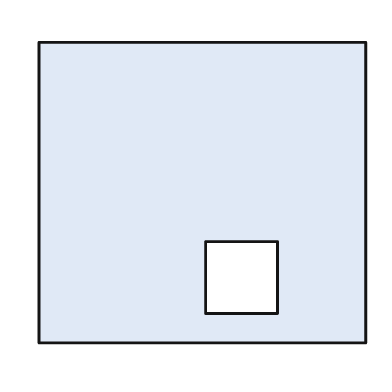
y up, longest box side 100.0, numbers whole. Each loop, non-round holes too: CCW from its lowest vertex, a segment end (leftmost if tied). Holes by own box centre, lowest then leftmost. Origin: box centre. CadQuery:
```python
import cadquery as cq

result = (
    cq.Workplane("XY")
    .moveTo(-50.0, -46.0)
    .lineTo(50.0, -46.0)
    .lineTo(50.0, 46.0)
    .lineTo(-50.0, 46.0)
    .close()
    .moveTo(1.0, -37.0)
    .lineTo(23.0, -37.0)
    .lineTo(23.0, -15.0)
    .lineTo(1.0, -15.0)
    .close()
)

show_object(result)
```